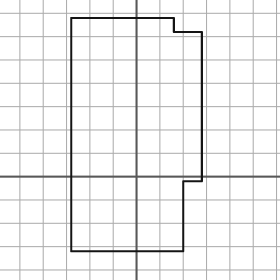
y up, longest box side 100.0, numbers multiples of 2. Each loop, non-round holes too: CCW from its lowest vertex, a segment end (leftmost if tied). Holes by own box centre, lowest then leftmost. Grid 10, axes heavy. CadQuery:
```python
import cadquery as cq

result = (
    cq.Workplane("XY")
    .moveTo(-28.0, -32.0)
    .lineTo(20.0, -32.0)
    .lineTo(20.0, -2.0)
    .lineTo(28.0, -2.0)
    .lineTo(28.0, 62.0)
    .lineTo(16.0, 62.0)
    .lineTo(16.0, 68.0)
    .lineTo(-28.0, 68.0)
    .close()
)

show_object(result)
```